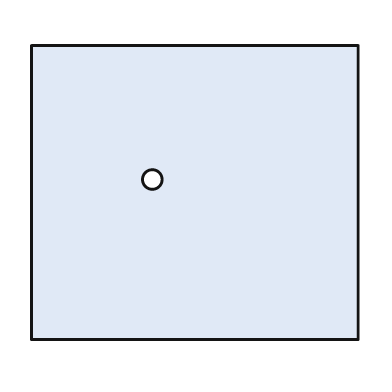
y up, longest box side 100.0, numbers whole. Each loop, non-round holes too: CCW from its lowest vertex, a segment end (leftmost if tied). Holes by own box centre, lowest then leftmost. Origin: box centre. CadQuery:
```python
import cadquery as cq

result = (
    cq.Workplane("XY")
    .moveTo(-50.0, -45.0)
    .lineTo(50.0, -45.0)
    .lineTo(50.0, 45.0)
    .lineTo(-50.0, 45.0)
    .close()
    .moveTo(-13.0, 4.0)
    .circle(3.0)
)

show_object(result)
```